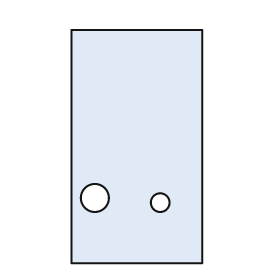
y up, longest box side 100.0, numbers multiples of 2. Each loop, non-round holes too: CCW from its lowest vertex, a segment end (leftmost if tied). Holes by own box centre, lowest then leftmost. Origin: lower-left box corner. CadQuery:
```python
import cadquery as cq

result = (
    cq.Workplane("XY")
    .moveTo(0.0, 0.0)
    .lineTo(56.0, 0.0)
    .lineTo(56.0, 100.0)
    .lineTo(0.0, 100.0)
    .close()
    .moveTo(38.0, 26.0)
    .circle(4.0)
    .moveTo(10.0, 28.0)
    .circle(6.0)
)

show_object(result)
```